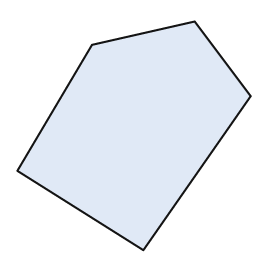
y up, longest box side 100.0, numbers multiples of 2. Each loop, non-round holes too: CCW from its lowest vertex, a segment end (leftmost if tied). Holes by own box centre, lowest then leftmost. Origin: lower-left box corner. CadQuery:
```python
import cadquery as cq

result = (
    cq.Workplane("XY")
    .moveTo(54.0, 0.0)
    .lineTo(100.0, 66.0)
    .lineTo(76.0, 98.0)
    .lineTo(32.0, 88.0)
    .lineTo(0.0, 34.0)
    .close()
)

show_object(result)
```